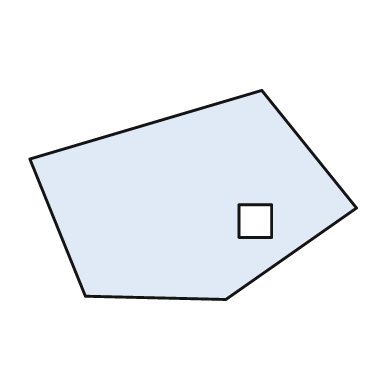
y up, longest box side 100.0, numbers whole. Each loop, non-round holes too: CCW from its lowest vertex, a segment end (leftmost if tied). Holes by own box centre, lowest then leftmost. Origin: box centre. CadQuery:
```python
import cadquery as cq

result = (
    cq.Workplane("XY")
    .moveTo(10.0, -32.0)
    .lineTo(50.0, -4.0)
    .lineTo(21.0, 32.0)
    .lineTo(-50.0, 11.0)
    .lineTo(-33.0, -31.0)
    .close()
    .moveTo(14.0, -13.0)
    .lineTo(24.0, -13.0)
    .lineTo(24.0, -3.0)
    .lineTo(14.0, -3.0)
    .close()
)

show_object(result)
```